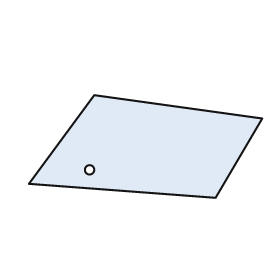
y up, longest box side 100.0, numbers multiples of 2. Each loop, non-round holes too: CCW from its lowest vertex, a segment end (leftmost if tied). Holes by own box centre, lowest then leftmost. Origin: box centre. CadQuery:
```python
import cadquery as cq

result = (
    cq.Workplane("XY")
    .moveTo(30.0, -22.0)
    .lineTo(50.0, 12.0)
    .lineTo(-22.0, 22.0)
    .lineTo(-50.0, -16.0)
    .close()
    .moveTo(-24.0, -10.0)
    .circle(2.0)
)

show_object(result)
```